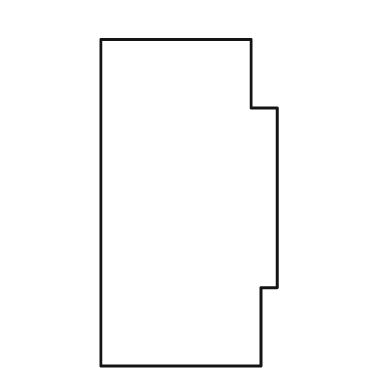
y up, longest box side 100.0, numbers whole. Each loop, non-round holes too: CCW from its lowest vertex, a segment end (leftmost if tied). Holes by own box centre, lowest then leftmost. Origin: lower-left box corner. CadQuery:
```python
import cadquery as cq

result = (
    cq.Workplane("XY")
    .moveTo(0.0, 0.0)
    .lineTo(49.0, 0.0)
    .lineTo(49.0, 24.0)
    .lineTo(54.0, 24.0)
    .lineTo(54.0, 79.0)
    .lineTo(46.0, 79.0)
    .lineTo(46.0, 100.0)
    .lineTo(0.0, 100.0)
    .close()
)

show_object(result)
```